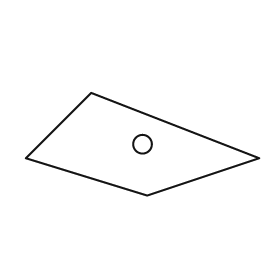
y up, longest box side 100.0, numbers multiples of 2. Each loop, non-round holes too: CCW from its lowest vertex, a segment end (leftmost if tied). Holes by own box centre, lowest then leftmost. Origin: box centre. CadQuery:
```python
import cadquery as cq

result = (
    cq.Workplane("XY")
    .moveTo(2.0, -22.0)
    .lineTo(50.0, -6.0)
    .lineTo(-22.0, 22.0)
    .lineTo(-50.0, -6.0)
    .close()
    .moveTo(0.0, 0.0)
    .circle(4.0)
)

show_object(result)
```